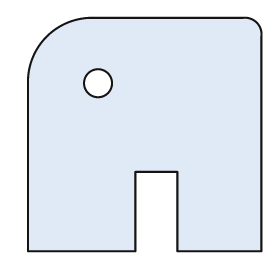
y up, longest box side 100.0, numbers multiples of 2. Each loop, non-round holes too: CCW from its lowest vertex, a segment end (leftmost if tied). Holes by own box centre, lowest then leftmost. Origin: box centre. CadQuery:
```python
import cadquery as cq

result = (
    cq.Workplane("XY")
    .moveTo(-50.0, -50.0)
    .lineTo(-4.0, -50.0)
    .lineTo(-4.0, -16.0)
    .lineTo(14.0, -16.0)
    .lineTo(14.0, -50.0)
    .lineTo(50.0, -50.0)
    .lineTo(50.0, 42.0)
    .threePointArc((48.0, 48.0), (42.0, 50.0))
    .lineTo(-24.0, 50.0)
    .threePointArc((-42.0, 42.0), (-50.0, 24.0))
    .close()
    .moveTo(-20.0, 22.0)
    .circle(6.0)
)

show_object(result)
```